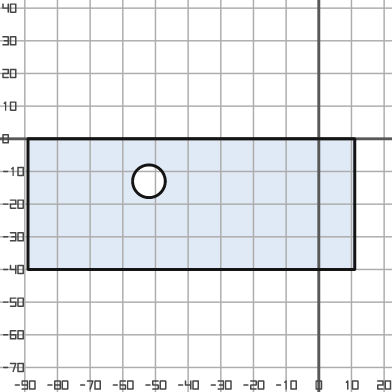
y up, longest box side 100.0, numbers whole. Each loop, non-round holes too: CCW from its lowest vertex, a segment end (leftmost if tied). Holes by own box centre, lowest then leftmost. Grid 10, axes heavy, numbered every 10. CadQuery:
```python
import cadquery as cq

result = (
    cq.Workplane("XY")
    .moveTo(-89.0, -40.0)
    .lineTo(11.0, -40.0)
    .lineTo(11.0, 0.0)
    .lineTo(-89.0, 0.0)
    .close()
    .moveTo(-52.0, -13.0)
    .circle(5.0)
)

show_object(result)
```